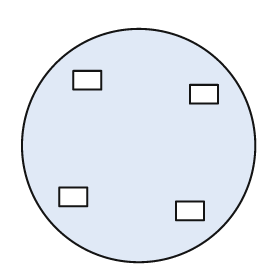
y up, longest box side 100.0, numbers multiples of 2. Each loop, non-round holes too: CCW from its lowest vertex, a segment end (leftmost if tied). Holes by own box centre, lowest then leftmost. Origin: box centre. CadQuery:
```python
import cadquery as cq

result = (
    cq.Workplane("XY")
    .moveTo(0.0, 0.0)
    .circle(50.0)
    .moveTo(16.0, -32.0)
    .lineTo(28.0, -32.0)
    .lineTo(28.0, -24.0)
    .lineTo(16.0, -24.0)
    .close()
    .moveTo(-34.0, -26.0)
    .lineTo(-22.0, -26.0)
    .lineTo(-22.0, -18.0)
    .lineTo(-34.0, -18.0)
    .close()
    .moveTo(22.0, 18.0)
    .lineTo(34.0, 18.0)
    .lineTo(34.0, 26.0)
    .lineTo(22.0, 26.0)
    .close()
    .moveTo(-28.0, 24.0)
    .lineTo(-16.0, 24.0)
    .lineTo(-16.0, 32.0)
    .lineTo(-28.0, 32.0)
    .close()
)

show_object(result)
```